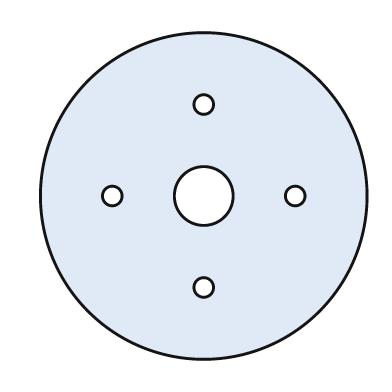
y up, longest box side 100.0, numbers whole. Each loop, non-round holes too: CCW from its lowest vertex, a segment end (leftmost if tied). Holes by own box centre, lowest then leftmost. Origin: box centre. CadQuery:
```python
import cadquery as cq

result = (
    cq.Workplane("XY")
    .moveTo(0.0, 0.0)
    .circle(50.0)
    .moveTo(0.0, -28.0)
    .circle(3.0)
    .moveTo(-28.0, 0.0)
    .circle(3.0)
    .moveTo(0.0, 0.0)
    .circle(9.0)
    .moveTo(28.0, 0.0)
    .circle(3.0)
    .moveTo(0.0, 28.0)
    .circle(3.0)
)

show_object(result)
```